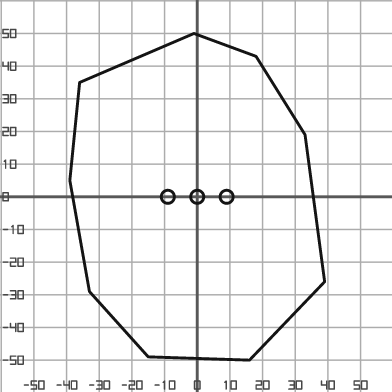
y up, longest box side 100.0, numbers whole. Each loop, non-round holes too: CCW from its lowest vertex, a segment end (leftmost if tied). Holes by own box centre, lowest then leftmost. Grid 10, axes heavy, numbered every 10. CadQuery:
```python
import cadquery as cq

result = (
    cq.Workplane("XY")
    .moveTo(16.0, -50.0)
    .lineTo(39.0, -26.0)
    .lineTo(33.0, 19.0)
    .lineTo(18.0, 43.0)
    .lineTo(-1.0, 50.0)
    .lineTo(-36.0, 35.0)
    .lineTo(-39.0, 5.0)
    .lineTo(-33.0, -29.0)
    .lineTo(-15.0, -49.0)
    .close()
    .moveTo(-9.0, 0.0)
    .circle(2.0)
    .moveTo(0.0, 0.0)
    .circle(2.0)
    .moveTo(9.0, 0.0)
    .circle(2.0)
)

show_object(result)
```